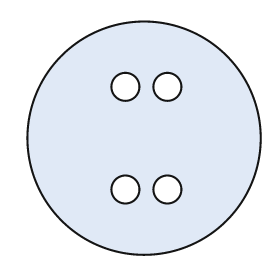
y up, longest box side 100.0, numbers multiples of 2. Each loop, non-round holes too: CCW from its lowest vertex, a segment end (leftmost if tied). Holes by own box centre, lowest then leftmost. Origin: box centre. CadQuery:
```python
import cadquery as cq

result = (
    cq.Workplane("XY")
    .moveTo(0.0, 0.0)
    .circle(50.0)
    .moveTo(-8.0, -22.0)
    .circle(6.0)
    .moveTo(10.0, -22.0)
    .circle(6.0)
    .moveTo(-8.0, 22.0)
    .circle(6.0)
    .moveTo(10.0, 22.0)
    .circle(6.0)
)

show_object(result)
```